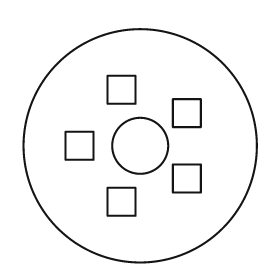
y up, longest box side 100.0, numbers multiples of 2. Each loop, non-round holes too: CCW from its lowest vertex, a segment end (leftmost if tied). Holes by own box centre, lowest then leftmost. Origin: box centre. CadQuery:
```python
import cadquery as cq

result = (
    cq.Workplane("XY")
    .moveTo(0.0, 0.0)
    .circle(50.0)
    .moveTo(-14.0, -30.0)
    .lineTo(-2.0, -30.0)
    .lineTo(-2.0, -18.0)
    .lineTo(-14.0, -18.0)
    .close()
    .moveTo(14.0, -20.0)
    .lineTo(26.0, -20.0)
    .lineTo(26.0, -8.0)
    .lineTo(14.0, -8.0)
    .close()
    .moveTo(-32.0, -6.0)
    .lineTo(-20.0, -6.0)
    .lineTo(-20.0, 6.0)
    .lineTo(-32.0, 6.0)
    .close()
    .moveTo(0.0, 0.0)
    .circle(12.0)
    .moveTo(14.0, 8.0)
    .lineTo(26.0, 8.0)
    .lineTo(26.0, 20.0)
    .lineTo(14.0, 20.0)
    .close()
    .moveTo(-14.0, 18.0)
    .lineTo(-2.0, 18.0)
    .lineTo(-2.0, 30.0)
    .lineTo(-14.0, 30.0)
    .close()
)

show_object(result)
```